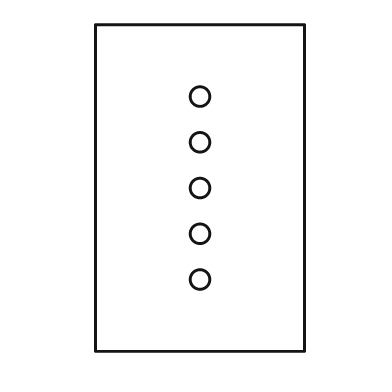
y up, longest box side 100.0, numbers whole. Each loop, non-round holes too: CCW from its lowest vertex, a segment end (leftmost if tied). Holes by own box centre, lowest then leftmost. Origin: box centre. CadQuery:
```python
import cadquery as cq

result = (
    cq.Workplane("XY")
    .moveTo(-32.0, -50.0)
    .lineTo(32.0, -50.0)
    .lineTo(32.0, 50.0)
    .lineTo(-32.0, 50.0)
    .close()
    .moveTo(0.0, -28.0)
    .circle(3.0)
    .moveTo(0.0, -14.0)
    .circle(3.0)
    .moveTo(0.0, 0.0)
    .circle(3.0)
    .moveTo(0.0, 14.0)
    .circle(3.0)
    .moveTo(0.0, 28.0)
    .circle(3.0)
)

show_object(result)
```